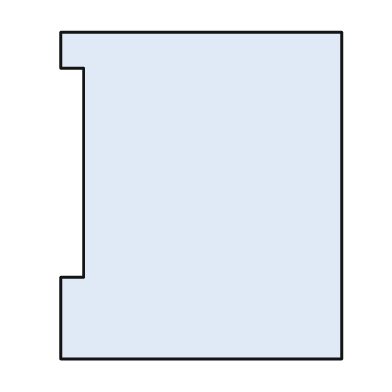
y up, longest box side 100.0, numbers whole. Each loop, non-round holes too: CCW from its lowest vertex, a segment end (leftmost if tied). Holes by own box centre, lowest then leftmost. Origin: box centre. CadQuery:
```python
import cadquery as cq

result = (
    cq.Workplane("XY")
    .moveTo(-43.0, -50.0)
    .lineTo(43.0, -50.0)
    .lineTo(43.0, 50.0)
    .lineTo(-43.0, 50.0)
    .lineTo(-43.0, 39.0)
    .lineTo(-36.0, 39.0)
    .lineTo(-36.0, -25.0)
    .lineTo(-43.0, -25.0)
    .close()
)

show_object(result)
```